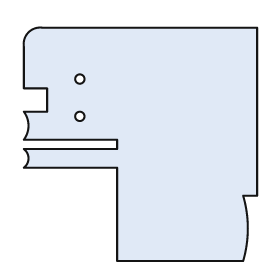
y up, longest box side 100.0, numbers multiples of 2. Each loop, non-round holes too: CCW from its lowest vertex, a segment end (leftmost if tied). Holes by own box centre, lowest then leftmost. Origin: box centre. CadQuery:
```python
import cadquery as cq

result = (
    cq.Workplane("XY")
    .moveTo(-10.0, -50.0)
    .lineTo(44.0, -50.0)
    .threePointArc((46.0, -36.0), (44.0, -22.0))
    .lineTo(50.0, -22.0)
    .lineTo(50.0, 50.0)
    .lineTo(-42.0, 50.0)
    .threePointArc((-48.0, 48.0), (-50.0, 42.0))
    .lineTo(-50.0, 24.0)
    .lineTo(-40.0, 24.0)
    .lineTo(-40.0, 14.0)
    .lineTo(-50.0, 14.0)
    .threePointArc((-48.0, 8.0), (-50.0, 2.0))
    .lineTo(-10.0, 2.0)
    .lineTo(-10.0, -2.0)
    .lineTo(-50.0, -2.0)
    .threePointArc((-48.0, -6.0), (-50.0, -10.0))
    .lineTo(-10.0, -10.0)
    .close()
    .moveTo(-26.0, 12.0)
    .circle(2.0)
    .moveTo(-26.0, 28.0)
    .circle(2.0)
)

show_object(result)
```